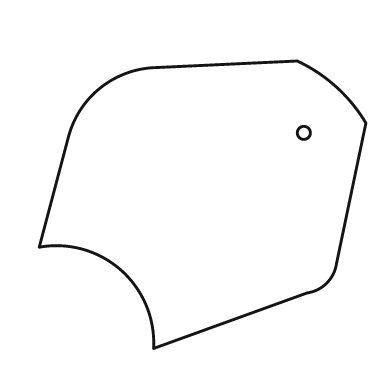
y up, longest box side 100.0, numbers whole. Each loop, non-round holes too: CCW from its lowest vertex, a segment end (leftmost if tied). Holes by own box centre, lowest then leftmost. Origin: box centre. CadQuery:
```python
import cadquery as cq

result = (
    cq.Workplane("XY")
    .moveTo(-15.0, -44.0)
    .lineTo(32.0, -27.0)
    .threePointArc((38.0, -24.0), (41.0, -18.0))
    .lineTo(50.0, 25.0)
    .threePointArc((41.0, 36.0), (29.0, 44.0))
    .lineTo(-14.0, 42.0)
    .threePointArc((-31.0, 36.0), (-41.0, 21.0))
    .lineTo(-50.0, -13.0)
    .threePointArc((-25.0, -20.0), (-15.0, -44.0))
    .close()
    .moveTo(31.0, 22.0)
    .circle(2.0)
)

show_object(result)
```